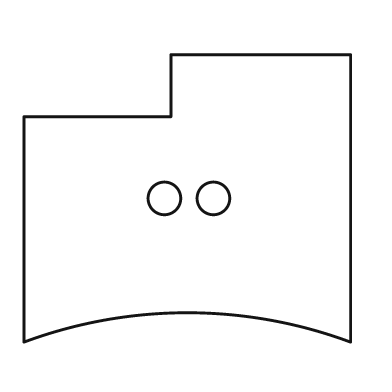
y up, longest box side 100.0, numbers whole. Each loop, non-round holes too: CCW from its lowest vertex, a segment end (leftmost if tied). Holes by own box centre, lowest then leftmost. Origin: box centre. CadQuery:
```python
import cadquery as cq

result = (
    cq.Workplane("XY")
    .moveTo(-50.0, -44.0)
    .threePointArc((0.0, -35.0), (50.0, -44.0))
    .lineTo(50.0, 44.0)
    .lineTo(-5.0, 44.0)
    .lineTo(-5.0, 25.0)
    .lineTo(-50.0, 25.0)
    .close()
    .moveTo(-7.0, 0.0)
    .circle(5.0)
    .moveTo(8.0, 0.0)
    .circle(5.0)
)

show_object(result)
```